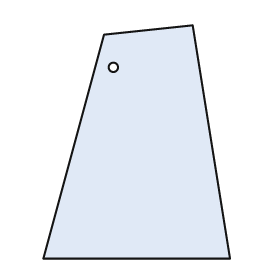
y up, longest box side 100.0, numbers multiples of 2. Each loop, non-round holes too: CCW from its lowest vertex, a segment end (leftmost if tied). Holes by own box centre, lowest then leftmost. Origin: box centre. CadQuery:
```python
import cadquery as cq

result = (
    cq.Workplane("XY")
    .moveTo(-40.0, -50.0)
    .lineTo(40.0, -50.0)
    .lineTo(24.0, 50.0)
    .lineTo(-14.0, 46.0)
    .close()
    .moveTo(-10.0, 32.0)
    .circle(2.0)
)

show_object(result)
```